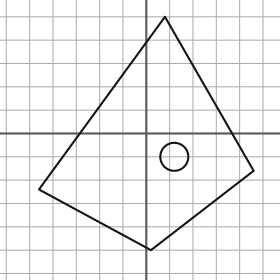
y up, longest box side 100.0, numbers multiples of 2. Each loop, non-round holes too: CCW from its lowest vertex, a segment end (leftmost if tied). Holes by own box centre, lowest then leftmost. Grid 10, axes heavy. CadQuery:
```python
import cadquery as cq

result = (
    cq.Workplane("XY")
    .moveTo(2.0, -50.0)
    .lineTo(46.0, -16.0)
    .lineTo(8.0, 50.0)
    .lineTo(-46.0, -24.0)
    .close()
    .moveTo(12.0, -10.0)
    .circle(6.0)
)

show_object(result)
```